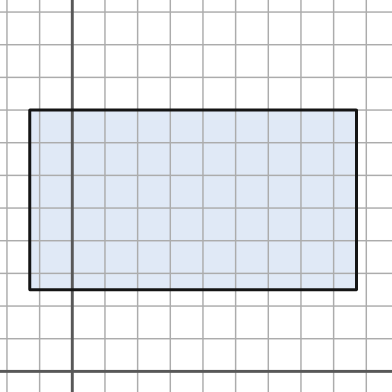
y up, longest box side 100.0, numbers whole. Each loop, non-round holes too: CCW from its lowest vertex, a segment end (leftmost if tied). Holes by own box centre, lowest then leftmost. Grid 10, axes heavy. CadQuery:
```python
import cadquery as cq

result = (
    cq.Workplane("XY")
    .moveTo(-13.0, 25.0)
    .lineTo(87.0, 25.0)
    .lineTo(87.0, 80.0)
    .lineTo(-13.0, 80.0)
    .close()
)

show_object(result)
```